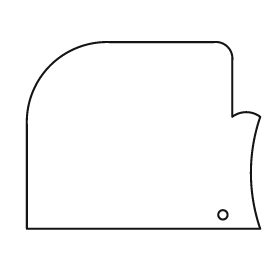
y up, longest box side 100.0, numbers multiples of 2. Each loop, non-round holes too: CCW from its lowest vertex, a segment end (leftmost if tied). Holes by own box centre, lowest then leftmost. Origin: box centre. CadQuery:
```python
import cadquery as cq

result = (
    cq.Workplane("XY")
    .moveTo(-50.0, -40.0)
    .lineTo(50.0, -40.0)
    .threePointArc((46.0, -16.0), (50.0, 8.0))
    .threePointArc((44.0, 10.0), (38.0, 8.0))
    .lineTo(38.0, 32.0)
    .threePointArc((36.0, 38.0), (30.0, 40.0))
    .lineTo(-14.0, 40.0)
    .threePointArc((-40.0, 30.0), (-50.0, 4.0))
    .close()
    .moveTo(34.0, -34.0)
    .circle(2.0)
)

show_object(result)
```